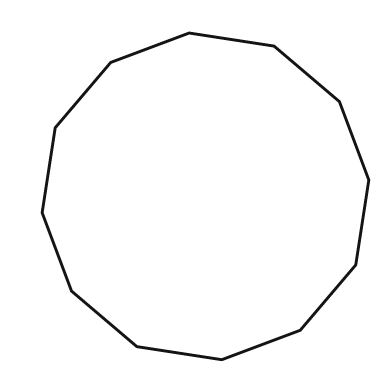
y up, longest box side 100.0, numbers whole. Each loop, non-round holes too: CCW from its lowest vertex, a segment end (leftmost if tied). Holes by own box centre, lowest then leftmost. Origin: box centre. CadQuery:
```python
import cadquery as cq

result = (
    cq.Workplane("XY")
    .moveTo(5.0, -50.0)
    .lineTo(29.0, -41.0)
    .lineTo(46.0, -21.0)
    .lineTo(50.0, 5.0)
    .lineTo(41.0, 29.0)
    .lineTo(21.0, 46.0)
    .lineTo(-5.0, 50.0)
    .lineTo(-29.0, 41.0)
    .lineTo(-46.0, 21.0)
    .lineTo(-50.0, -5.0)
    .lineTo(-41.0, -29.0)
    .lineTo(-21.0, -46.0)
    .close()
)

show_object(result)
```